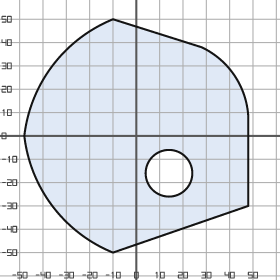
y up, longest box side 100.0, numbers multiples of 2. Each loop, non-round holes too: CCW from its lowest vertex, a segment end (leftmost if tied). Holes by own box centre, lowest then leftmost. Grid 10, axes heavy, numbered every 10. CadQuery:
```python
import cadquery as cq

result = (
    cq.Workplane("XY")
    .moveTo(-10.0, -50.0)
    .lineTo(48.0, -30.0)
    .lineTo(48.0, 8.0)
    .threePointArc((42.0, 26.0), (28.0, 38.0))
    .lineTo(-10.0, 50.0)
    .threePointArc((-36.0, 30.0), (-48.0, 0.0))
    .threePointArc((-36.0, -30.0), (-10.0, -50.0))
    .close()
    .moveTo(14.0, -16.0)
    .circle(10.0)
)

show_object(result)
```